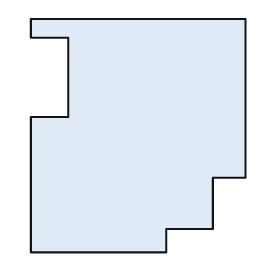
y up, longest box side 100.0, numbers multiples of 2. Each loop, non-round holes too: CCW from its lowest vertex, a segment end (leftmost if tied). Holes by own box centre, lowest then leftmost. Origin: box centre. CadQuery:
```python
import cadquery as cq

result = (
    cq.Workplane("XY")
    .moveTo(-46.0, -50.0)
    .lineTo(12.0, -50.0)
    .lineTo(12.0, -40.0)
    .lineTo(32.0, -40.0)
    .lineTo(32.0, -18.0)
    .lineTo(46.0, -18.0)
    .lineTo(46.0, 50.0)
    .lineTo(-46.0, 50.0)
    .lineTo(-46.0, 42.0)
    .lineTo(-30.0, 42.0)
    .lineTo(-30.0, 8.0)
    .lineTo(-46.0, 8.0)
    .close()
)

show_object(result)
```